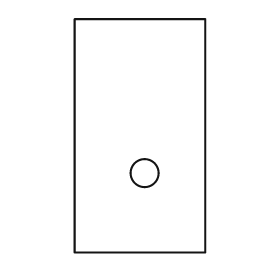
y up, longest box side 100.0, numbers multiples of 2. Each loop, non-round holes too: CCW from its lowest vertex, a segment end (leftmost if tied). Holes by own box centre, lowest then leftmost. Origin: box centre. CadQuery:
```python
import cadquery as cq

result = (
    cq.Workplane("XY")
    .moveTo(-28.0, -50.0)
    .lineTo(28.0, -50.0)
    .lineTo(28.0, 50.0)
    .lineTo(-28.0, 50.0)
    .close()
    .moveTo(2.0, -16.0)
    .circle(6.0)
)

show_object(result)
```